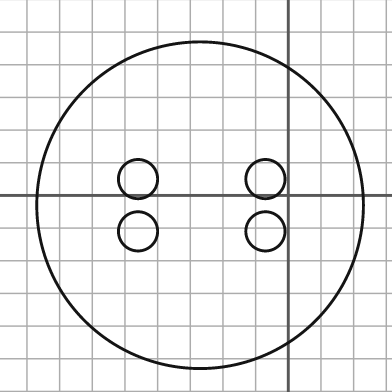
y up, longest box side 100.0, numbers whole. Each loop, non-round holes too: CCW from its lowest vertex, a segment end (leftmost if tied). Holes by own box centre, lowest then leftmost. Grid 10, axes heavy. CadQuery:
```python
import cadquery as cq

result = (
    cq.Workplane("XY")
    .moveTo(-27.0, -3.0)
    .circle(50.0)
    .moveTo(-46.0, -11.0)
    .circle(6.0)
    .moveTo(-7.0, -11.0)
    .circle(6.0)
    .moveTo(-46.0, 5.0)
    .circle(6.0)
    .moveTo(-7.0, 5.0)
    .circle(6.0)
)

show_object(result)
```